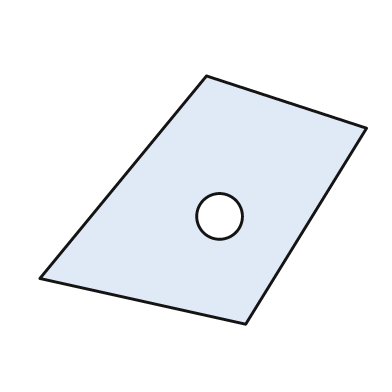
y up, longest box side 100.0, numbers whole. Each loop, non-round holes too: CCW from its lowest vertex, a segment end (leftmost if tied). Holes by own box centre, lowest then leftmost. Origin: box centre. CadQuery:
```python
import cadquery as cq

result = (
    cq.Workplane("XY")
    .moveTo(13.0, -38.0)
    .lineTo(50.0, 22.0)
    .lineTo(1.0, 38.0)
    .lineTo(-50.0, -24.0)
    .close()
    .moveTo(5.0, -5.0)
    .circle(7.0)
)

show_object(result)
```